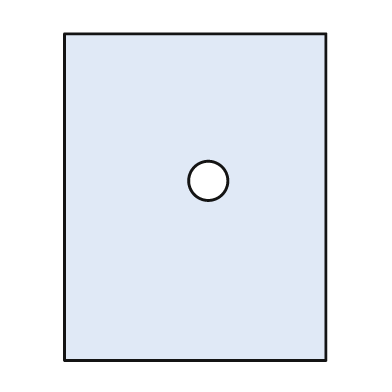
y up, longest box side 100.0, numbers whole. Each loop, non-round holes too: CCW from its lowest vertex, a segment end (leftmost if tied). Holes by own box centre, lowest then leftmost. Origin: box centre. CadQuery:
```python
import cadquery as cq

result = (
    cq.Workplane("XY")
    .moveTo(-40.0, -50.0)
    .lineTo(40.0, -50.0)
    .lineTo(40.0, 50.0)
    .lineTo(-40.0, 50.0)
    .close()
    .moveTo(4.0, 5.0)
    .circle(6.0)
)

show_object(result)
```